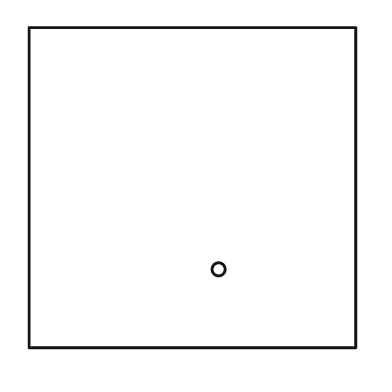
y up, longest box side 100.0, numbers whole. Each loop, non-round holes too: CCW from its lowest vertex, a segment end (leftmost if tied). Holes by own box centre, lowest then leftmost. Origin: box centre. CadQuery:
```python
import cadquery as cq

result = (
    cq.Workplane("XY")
    .moveTo(-50.0, -49.0)
    .lineTo(50.0, -49.0)
    .lineTo(50.0, 49.0)
    .lineTo(-50.0, 49.0)
    .close()
    .moveTo(8.0, -25.0)
    .circle(2.0)
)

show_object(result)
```